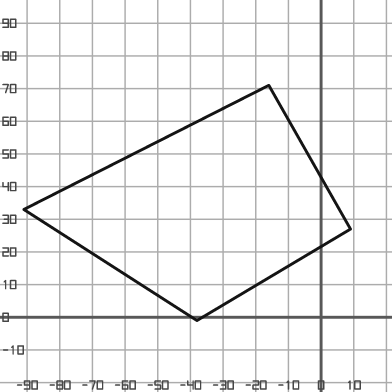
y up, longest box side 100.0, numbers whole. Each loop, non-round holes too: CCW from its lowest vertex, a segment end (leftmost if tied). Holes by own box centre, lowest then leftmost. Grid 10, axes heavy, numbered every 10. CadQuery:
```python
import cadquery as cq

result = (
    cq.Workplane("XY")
    .moveTo(-38.0, -1.0)
    .lineTo(9.0, 27.0)
    .lineTo(-16.0, 71.0)
    .lineTo(-91.0, 33.0)
    .close()
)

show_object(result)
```